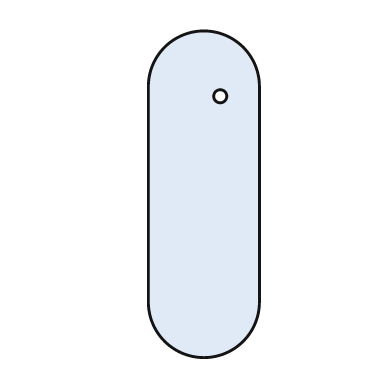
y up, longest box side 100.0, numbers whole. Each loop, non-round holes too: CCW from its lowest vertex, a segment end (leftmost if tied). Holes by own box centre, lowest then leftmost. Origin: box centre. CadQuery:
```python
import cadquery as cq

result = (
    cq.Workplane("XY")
    .moveTo(-17.0, -33.0)
    .threePointArc((0.0, -50.0), (17.0, -33.0))
    .lineTo(17.0, 33.0)
    .threePointArc((0.0, 50.0), (-17.0, 33.0))
    .close()
    .moveTo(5.0, 30.0)
    .circle(2.0)
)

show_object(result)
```